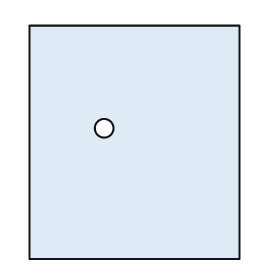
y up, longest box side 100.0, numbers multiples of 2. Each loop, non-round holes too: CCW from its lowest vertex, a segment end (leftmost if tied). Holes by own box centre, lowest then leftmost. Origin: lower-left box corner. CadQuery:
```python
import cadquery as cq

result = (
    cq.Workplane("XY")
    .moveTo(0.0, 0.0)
    .lineTo(90.0, 0.0)
    .lineTo(90.0, 100.0)
    .lineTo(0.0, 100.0)
    .close()
    .moveTo(32.0, 56.0)
    .circle(4.0)
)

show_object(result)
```